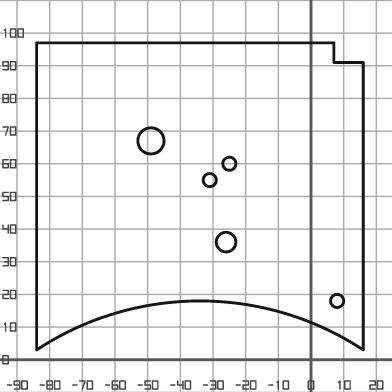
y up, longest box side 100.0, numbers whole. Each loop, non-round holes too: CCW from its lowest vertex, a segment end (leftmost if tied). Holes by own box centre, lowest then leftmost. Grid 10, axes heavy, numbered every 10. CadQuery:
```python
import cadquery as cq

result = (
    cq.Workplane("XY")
    .moveTo(-84.0, 3.0)
    .threePointArc((-34.0, 18.0), (16.0, 3.0))
    .lineTo(16.0, 91.0)
    .lineTo(7.0, 91.0)
    .lineTo(7.0, 97.0)
    .lineTo(-84.0, 97.0)
    .close()
    .moveTo(8.0, 18.0)
    .circle(2.0)
    .moveTo(-26.0, 36.0)
    .circle(3.0)
    .moveTo(-31.0, 55.0)
    .circle(2.0)
    .moveTo(-25.0, 60.0)
    .circle(2.0)
    .moveTo(-49.0, 67.0)
    .circle(4.0)
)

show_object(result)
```